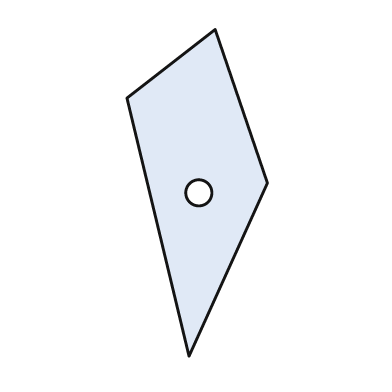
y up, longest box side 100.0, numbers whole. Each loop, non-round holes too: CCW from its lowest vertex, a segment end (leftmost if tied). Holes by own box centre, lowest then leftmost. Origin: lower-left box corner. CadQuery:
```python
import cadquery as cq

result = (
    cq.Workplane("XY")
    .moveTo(19.0, 0.0)
    .lineTo(43.0, 53.0)
    .lineTo(27.0, 100.0)
    .lineTo(0.0, 79.0)
    .close()
    .moveTo(22.0, 50.0)
    .circle(4.0)
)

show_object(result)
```